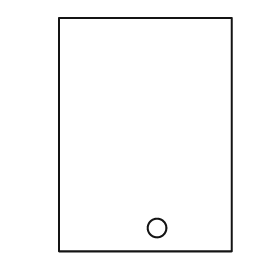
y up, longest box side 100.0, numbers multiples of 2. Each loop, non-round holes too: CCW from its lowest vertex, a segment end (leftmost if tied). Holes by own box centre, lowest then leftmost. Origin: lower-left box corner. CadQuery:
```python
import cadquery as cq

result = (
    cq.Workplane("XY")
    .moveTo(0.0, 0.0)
    .lineTo(74.0, 0.0)
    .lineTo(74.0, 100.0)
    .lineTo(0.0, 100.0)
    .close()
    .moveTo(42.0, 10.0)
    .circle(4.0)
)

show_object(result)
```